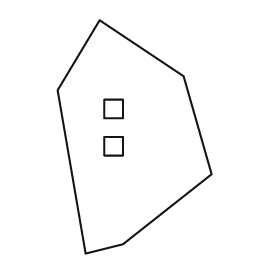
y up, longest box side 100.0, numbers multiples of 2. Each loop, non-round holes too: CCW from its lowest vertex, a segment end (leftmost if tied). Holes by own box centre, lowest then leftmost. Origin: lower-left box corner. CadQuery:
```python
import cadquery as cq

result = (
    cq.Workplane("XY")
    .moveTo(12.0, 0.0)
    .lineTo(28.0, 4.0)
    .lineTo(66.0, 34.0)
    .lineTo(54.0, 76.0)
    .lineTo(18.0, 100.0)
    .lineTo(0.0, 70.0)
    .close()
    .moveTo(20.0, 42.0)
    .lineTo(28.0, 42.0)
    .lineTo(28.0, 50.0)
    .lineTo(20.0, 50.0)
    .close()
    .moveTo(20.0, 58.0)
    .lineTo(28.0, 58.0)
    .lineTo(28.0, 66.0)
    .lineTo(20.0, 66.0)
    .close()
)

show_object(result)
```